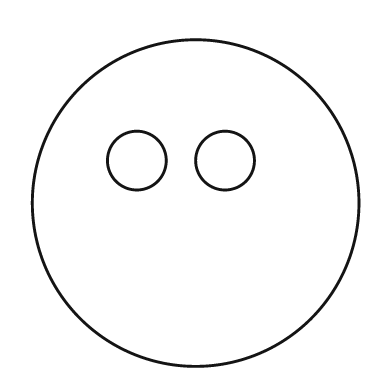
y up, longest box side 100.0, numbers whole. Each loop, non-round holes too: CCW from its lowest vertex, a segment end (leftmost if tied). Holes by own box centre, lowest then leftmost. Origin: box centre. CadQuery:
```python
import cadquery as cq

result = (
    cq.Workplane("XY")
    .moveTo(0.0, 0.0)
    .circle(50.0)
    .moveTo(-18.0, 13.0)
    .circle(9.0)
    .moveTo(9.0, 13.0)
    .circle(9.0)
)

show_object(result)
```